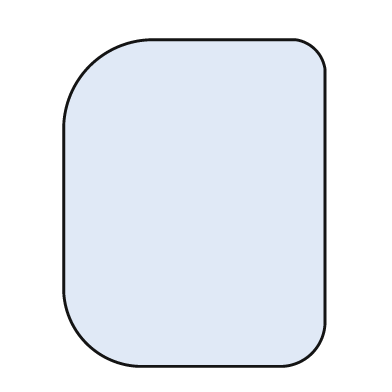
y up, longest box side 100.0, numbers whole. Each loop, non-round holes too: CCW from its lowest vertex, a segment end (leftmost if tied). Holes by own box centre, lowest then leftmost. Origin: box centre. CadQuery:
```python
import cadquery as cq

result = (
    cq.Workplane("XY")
    .moveTo(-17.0, -50.0)
    .lineTo(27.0, -50.0)
    .threePointArc((36.0, -46.0), (40.0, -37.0))
    .lineTo(40.0, 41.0)
    .threePointArc((37.0, 47.0), (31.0, 50.0))
    .lineTo(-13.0, 50.0)
    .threePointArc((-32.0, 42.0), (-40.0, 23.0))
    .lineTo(-40.0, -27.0)
    .threePointArc((-33.0, -43.0), (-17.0, -50.0))
    .close()
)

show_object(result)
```